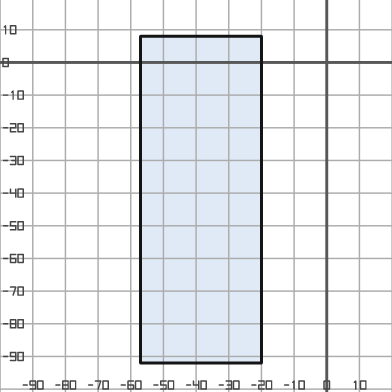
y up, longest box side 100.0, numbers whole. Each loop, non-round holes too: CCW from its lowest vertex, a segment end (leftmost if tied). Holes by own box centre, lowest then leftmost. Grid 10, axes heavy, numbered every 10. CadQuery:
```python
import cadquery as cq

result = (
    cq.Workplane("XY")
    .moveTo(-57.0, -92.0)
    .lineTo(-20.0, -92.0)
    .lineTo(-20.0, 8.0)
    .lineTo(-57.0, 8.0)
    .close()
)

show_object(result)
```